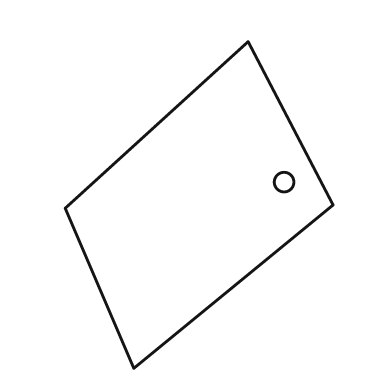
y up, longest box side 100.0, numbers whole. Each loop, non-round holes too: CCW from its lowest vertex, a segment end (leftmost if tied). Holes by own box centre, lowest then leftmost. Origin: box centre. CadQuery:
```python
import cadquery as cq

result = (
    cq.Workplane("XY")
    .moveTo(-20.0, -50.0)
    .lineTo(41.0, 0.0)
    .lineTo(15.0, 50.0)
    .lineTo(-41.0, -1.0)
    .close()
    .moveTo(26.0, 7.0)
    .circle(3.0)
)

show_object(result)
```